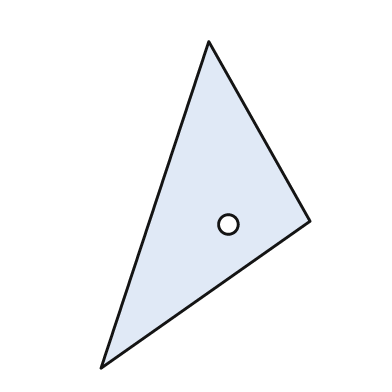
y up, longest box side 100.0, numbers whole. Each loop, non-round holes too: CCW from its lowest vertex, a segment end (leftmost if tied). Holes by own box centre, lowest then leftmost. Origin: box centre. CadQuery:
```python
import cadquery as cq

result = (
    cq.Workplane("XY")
    .moveTo(-32.0, -50.0)
    .lineTo(32.0, -5.0)
    .lineTo(1.0, 50.0)
    .close()
    .moveTo(7.0, -6.0)
    .circle(3.0)
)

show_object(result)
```